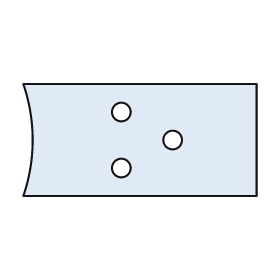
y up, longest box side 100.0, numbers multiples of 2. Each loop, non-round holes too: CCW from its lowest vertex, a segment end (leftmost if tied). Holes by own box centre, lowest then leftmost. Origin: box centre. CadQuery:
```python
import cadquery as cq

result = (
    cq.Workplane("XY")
    .moveTo(-50.0, -24.0)
    .lineTo(50.0, -24.0)
    .lineTo(50.0, 24.0)
    .lineTo(-50.0, 24.0)
    .threePointArc((-46.0, 0.0), (-50.0, -24.0))
    .close()
    .moveTo(-8.0, -12.0)
    .circle(4.0)
    .moveTo(14.0, 0.0)
    .circle(4.0)
    .moveTo(-8.0, 12.0)
    .circle(4.0)
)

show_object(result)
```